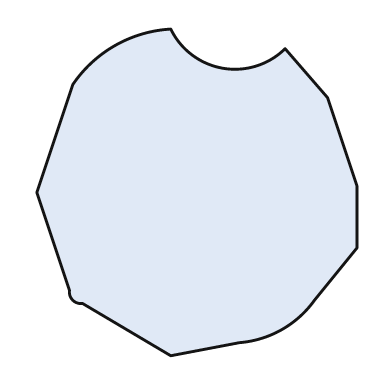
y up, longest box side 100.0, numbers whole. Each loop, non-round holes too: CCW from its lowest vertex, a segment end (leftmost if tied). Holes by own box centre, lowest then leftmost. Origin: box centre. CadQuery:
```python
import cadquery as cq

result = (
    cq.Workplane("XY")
    .moveTo(-8.0, -50.0)
    .lineTo(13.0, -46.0)
    .threePointArc((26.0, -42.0), (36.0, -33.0))
    .lineTo(49.0, -17.0)
    .lineTo(49.0, 2.0)
    .lineTo(40.0, 29.0)
    .lineTo(27.0, 44.0)
    .threePointArc((8.0, 38.0), (-8.0, 50.0))
    .threePointArc((-25.0, 45.0), (-38.0, 33.0))
    .lineTo(-49.0, 0.0)
    .lineTo(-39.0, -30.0)
    .threePointArc((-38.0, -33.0), (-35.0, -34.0))
    .close()
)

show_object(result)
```